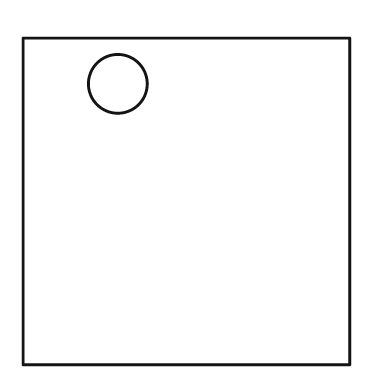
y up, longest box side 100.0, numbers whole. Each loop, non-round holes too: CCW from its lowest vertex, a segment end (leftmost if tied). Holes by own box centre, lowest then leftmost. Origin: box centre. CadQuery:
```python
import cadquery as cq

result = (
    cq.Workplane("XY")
    .moveTo(-50.0, -50.0)
    .lineTo(50.0, -50.0)
    .lineTo(50.0, 50.0)
    .lineTo(-50.0, 50.0)
    .close()
    .moveTo(-21.0, 36.0)
    .circle(9.0)
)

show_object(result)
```